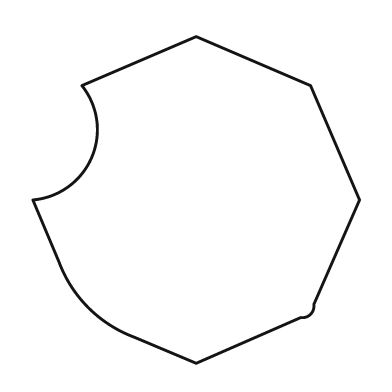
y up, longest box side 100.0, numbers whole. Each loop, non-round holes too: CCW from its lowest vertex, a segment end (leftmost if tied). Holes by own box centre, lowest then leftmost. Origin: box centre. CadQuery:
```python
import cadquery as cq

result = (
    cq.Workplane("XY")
    .moveTo(0.0, -50.0)
    .lineTo(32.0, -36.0)
    .threePointArc((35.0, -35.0), (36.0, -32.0))
    .lineTo(50.0, 0.0)
    .lineTo(35.0, 35.0)
    .lineTo(0.0, 50.0)
    .lineTo(-35.0, 35.0)
    .threePointArc((-32.0, 13.0), (-50.0, 0.0))
    .lineTo(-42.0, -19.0)
    .threePointArc((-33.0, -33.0), (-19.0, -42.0))
    .close()
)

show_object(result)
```